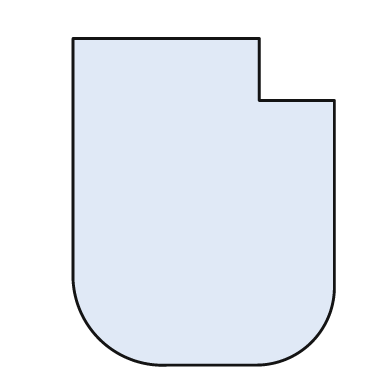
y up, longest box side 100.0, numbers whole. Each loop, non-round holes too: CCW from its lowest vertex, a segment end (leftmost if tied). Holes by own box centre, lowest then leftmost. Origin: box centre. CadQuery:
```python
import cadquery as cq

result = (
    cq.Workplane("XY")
    .moveTo(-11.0, -50.0)
    .lineTo(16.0, -50.0)
    .threePointArc((33.0, -43.0), (40.0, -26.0))
    .lineTo(40.0, 31.0)
    .lineTo(17.0, 31.0)
    .lineTo(17.0, 50.0)
    .lineTo(-40.0, 50.0)
    .lineTo(-40.0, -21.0)
    .threePointArc((-32.0, -42.0), (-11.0, -50.0))
    .close()
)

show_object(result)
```